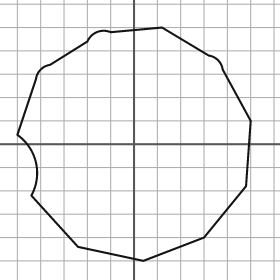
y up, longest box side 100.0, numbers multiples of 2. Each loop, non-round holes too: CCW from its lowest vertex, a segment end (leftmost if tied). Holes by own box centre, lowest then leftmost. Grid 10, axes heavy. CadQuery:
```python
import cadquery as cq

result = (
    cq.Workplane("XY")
    .moveTo(4.0, -50.0)
    .lineTo(30.0, -40.0)
    .lineTo(48.0, -18.0)
    .lineTo(50.0, 10.0)
    .lineTo(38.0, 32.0)
    .threePointArc((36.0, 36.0), (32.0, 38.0))
    .lineTo(12.0, 50.0)
    .lineTo(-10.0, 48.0)
    .threePointArc((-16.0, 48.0), (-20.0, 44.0))
    .lineTo(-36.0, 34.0)
    .threePointArc((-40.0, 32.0), (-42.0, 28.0))
    .lineTo(-50.0, 4.0)
    .threePointArc((-42.0, -8.0), (-44.0, -22.0))
    .lineTo(-24.0, -44.0)
    .close()
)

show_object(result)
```